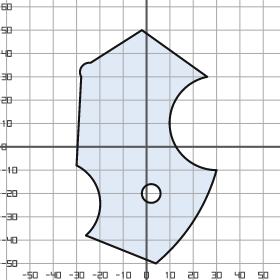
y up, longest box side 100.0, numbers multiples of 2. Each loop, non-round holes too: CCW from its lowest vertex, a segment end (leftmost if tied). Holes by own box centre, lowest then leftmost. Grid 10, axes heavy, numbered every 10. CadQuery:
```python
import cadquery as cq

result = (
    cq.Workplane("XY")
    .moveTo(4.0, -50.0)
    .threePointArc((20.0, -32.0), (30.0, -10.0))
    .threePointArc((10.0, 8.0), (26.0, 30.0))
    .lineTo(-2.0, 50.0)
    .lineTo(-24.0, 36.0)
    .threePointArc((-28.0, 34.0), (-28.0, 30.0))
    .lineTo(-30.0, -8.0)
    .threePointArc((-20.0, -22.0), (-26.0, -38.0))
    .close()
    .moveTo(2.0, -20.0)
    .circle(4.0)
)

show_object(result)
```